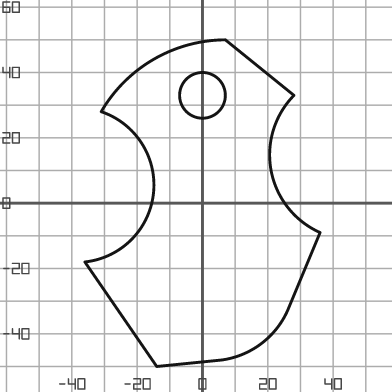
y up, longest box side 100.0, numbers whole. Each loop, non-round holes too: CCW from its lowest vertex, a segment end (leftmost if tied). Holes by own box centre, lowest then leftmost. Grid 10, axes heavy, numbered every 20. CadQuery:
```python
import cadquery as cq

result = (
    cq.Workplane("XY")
    .moveTo(-14.0, -50.0)
    .lineTo(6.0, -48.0)
    .threePointArc((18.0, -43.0), (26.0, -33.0))
    .lineTo(36.0, -9.0)
    .threePointArc((21.0, 10.0), (28.0, 33.0))
    .lineTo(7.0, 50.0)
    .threePointArc((-15.0, 44.0), (-31.0, 28.0))
    .threePointArc((-15.0, 3.0), (-36.0, -18.0))
    .close()
    .moveTo(0.0, 33.0)
    .circle(7.0)
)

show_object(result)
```